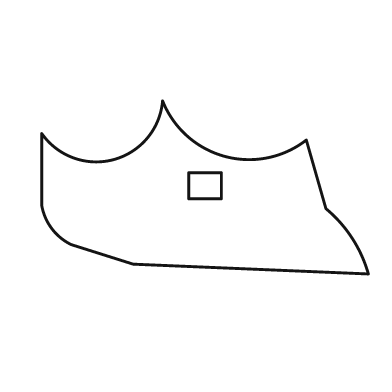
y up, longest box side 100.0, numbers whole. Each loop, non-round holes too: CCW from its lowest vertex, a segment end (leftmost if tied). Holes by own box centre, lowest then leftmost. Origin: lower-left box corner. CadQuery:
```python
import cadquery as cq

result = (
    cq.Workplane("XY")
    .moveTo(100.0, 0.0)
    .threePointArc((95.0, 11.0), (87.0, 20.0))
    .lineTo(81.0, 41.0)
    .threePointArc((56.0, 36.0), (37.0, 53.0))
    .threePointArc((22.0, 35.0), (0.0, 43.0))
    .lineTo(0.0, 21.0)
    .threePointArc((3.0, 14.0), (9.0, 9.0))
    .lineTo(28.0, 3.0)
    .close()
    .moveTo(45.0, 23.0)
    .lineTo(55.0, 23.0)
    .lineTo(55.0, 31.0)
    .lineTo(45.0, 31.0)
    .close()
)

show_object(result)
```